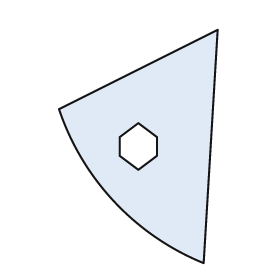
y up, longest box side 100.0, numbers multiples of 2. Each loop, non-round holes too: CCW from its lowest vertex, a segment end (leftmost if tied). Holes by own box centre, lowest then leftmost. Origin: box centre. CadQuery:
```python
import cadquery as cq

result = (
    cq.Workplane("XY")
    .moveTo(28.0, -50.0)
    .lineTo(34.0, 50.0)
    .lineTo(-34.0, 16.0)
    .threePointArc((-10.0, -24.0), (28.0, -50.0))
    .close()
    .moveTo(0.0, -10.0)
    .lineTo(8.0, -4.0)
    .lineTo(8.0, 4.0)
    .lineTo(0.0, 10.0)
    .lineTo(-8.0, 4.0)
    .lineTo(-8.0, -4.0)
    .close()
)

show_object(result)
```